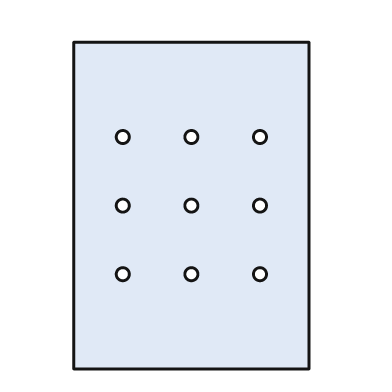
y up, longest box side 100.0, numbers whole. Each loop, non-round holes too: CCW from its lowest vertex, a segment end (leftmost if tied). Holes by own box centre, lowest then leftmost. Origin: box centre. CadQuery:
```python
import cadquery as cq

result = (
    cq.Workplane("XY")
    .moveTo(-36.0, -50.0)
    .lineTo(36.0, -50.0)
    .lineTo(36.0, 50.0)
    .lineTo(-36.0, 50.0)
    .close()
    .moveTo(-21.0, -21.0)
    .circle(2.0)
    .moveTo(0.0, -21.0)
    .circle(2.0)
    .moveTo(21.0, -21.0)
    .circle(2.0)
    .moveTo(-21.0, 0.0)
    .circle(2.0)
    .moveTo(0.0, 0.0)
    .circle(2.0)
    .moveTo(21.0, 0.0)
    .circle(2.0)
    .moveTo(-21.0, 21.0)
    .circle(2.0)
    .moveTo(0.0, 21.0)
    .circle(2.0)
    .moveTo(21.0, 21.0)
    .circle(2.0)
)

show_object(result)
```